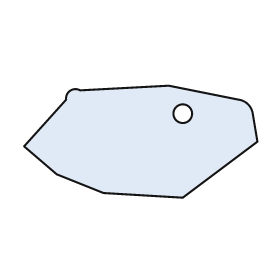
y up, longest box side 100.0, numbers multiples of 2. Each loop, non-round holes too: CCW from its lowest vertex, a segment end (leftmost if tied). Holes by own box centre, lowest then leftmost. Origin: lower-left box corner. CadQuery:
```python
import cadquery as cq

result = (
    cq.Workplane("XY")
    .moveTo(68.0, 0.0)
    .lineTo(100.0, 24.0)
    .lineTo(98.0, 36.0)
    .threePointArc((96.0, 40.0), (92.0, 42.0))
    .lineTo(62.0, 48.0)
    .lineTo(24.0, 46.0)
    .threePointArc((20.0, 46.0), (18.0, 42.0))
    .lineTo(0.0, 22.0)
    .lineTo(14.0, 10.0)
    .lineTo(34.0, 2.0)
    .close()
    .moveTo(68.0, 36.0)
    .circle(4.0)
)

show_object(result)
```